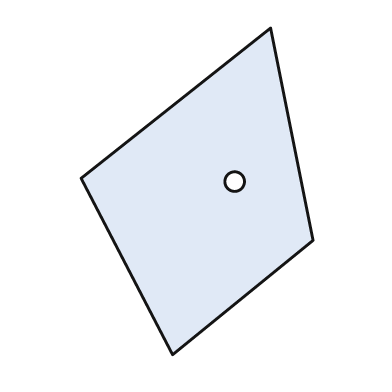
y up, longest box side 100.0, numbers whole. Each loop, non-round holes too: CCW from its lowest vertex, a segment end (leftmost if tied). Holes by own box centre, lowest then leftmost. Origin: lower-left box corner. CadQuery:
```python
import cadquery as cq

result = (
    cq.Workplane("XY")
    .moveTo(28.0, 0.0)
    .lineTo(71.0, 35.0)
    .lineTo(58.0, 100.0)
    .lineTo(0.0, 54.0)
    .close()
    .moveTo(47.0, 53.0)
    .circle(3.0)
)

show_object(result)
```